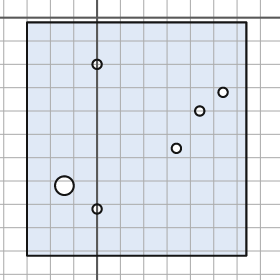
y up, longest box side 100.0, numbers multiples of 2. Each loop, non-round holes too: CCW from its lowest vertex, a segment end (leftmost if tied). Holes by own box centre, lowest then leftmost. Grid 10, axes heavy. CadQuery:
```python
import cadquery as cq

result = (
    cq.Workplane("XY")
    .moveTo(-30.0, -102.0)
    .lineTo(64.0, -102.0)
    .lineTo(64.0, -2.0)
    .lineTo(-30.0, -2.0)
    .close()
    .moveTo(0.0, -82.0)
    .circle(2.0)
    .moveTo(-14.0, -72.0)
    .circle(4.0)
    .moveTo(34.0, -56.0)
    .circle(2.0)
    .moveTo(44.0, -40.0)
    .circle(2.0)
    .moveTo(54.0, -32.0)
    .circle(2.0)
    .moveTo(0.0, -20.0)
    .circle(2.0)
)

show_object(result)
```